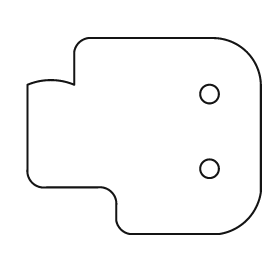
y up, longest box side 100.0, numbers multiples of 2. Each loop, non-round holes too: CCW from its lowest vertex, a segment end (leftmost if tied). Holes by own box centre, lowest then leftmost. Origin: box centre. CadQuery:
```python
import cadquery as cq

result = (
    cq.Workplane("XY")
    .moveTo(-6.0, -42.0)
    .lineTo(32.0, -42.0)
    .threePointArc((44.0, -36.0), (50.0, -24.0))
    .lineTo(50.0, 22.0)
    .threePointArc((44.0, 36.0), (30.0, 42.0))
    .lineTo(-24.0, 42.0)
    .threePointArc((-28.0, 40.0), (-30.0, 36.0))
    .lineTo(-30.0, 22.0)
    .threePointArc((-40.0, 24.0), (-50.0, 22.0))
    .lineTo(-50.0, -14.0)
    .threePointArc((-48.0, -20.0), (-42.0, -22.0))
    .lineTo(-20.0, -22.0)
    .threePointArc((-14.0, -24.0), (-12.0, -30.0))
    .lineTo(-12.0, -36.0)
    .threePointArc((-10.0, -40.0), (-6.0, -42.0))
    .close()
    .moveTo(28.0, -14.0)
    .circle(4.0)
    .moveTo(28.0, 18.0)
    .circle(4.0)
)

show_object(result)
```